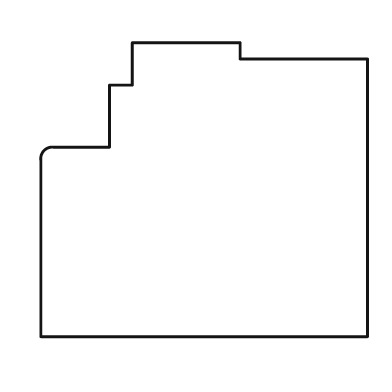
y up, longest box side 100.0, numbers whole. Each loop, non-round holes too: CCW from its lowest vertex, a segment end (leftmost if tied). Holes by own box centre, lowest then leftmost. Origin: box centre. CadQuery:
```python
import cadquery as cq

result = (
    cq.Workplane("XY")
    .moveTo(-50.0, -45.0)
    .lineTo(50.0, -45.0)
    .lineTo(50.0, 40.0)
    .lineTo(11.0, 40.0)
    .lineTo(11.0, 45.0)
    .lineTo(-22.0, 45.0)
    .lineTo(-22.0, 32.0)
    .lineTo(-29.0, 32.0)
    .lineTo(-29.0, 13.0)
    .lineTo(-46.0, 13.0)
    .threePointArc((-49.0, 12.0), (-50.0, 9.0))
    .close()
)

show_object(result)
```